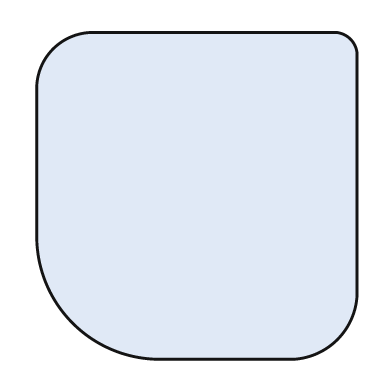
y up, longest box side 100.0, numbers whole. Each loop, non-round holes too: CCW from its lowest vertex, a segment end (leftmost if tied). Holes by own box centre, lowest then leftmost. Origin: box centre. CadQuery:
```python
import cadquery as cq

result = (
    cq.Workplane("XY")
    .moveTo(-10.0, -50.0)
    .lineTo(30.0, -50.0)
    .threePointArc((43.0, -44.0), (49.0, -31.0))
    .lineTo(49.0, 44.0)
    .threePointArc((47.0, 48.0), (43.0, 50.0))
    .lineTo(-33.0, 50.0)
    .threePointArc((-44.0, 45.0), (-49.0, 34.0))
    .lineTo(-49.0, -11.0)
    .threePointArc((-38.0, -39.0), (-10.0, -50.0))
    .close()
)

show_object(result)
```